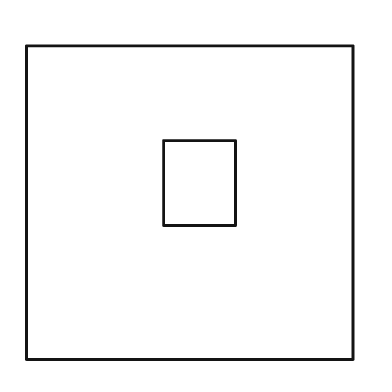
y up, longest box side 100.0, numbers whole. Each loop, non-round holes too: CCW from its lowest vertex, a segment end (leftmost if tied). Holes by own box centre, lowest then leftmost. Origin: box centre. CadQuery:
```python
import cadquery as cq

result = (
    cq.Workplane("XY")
    .moveTo(-50.0, -48.0)
    .lineTo(50.0, -48.0)
    .lineTo(50.0, 48.0)
    .lineTo(-50.0, 48.0)
    .close()
    .moveTo(-8.0, -7.0)
    .lineTo(14.0, -7.0)
    .lineTo(14.0, 19.0)
    .lineTo(-8.0, 19.0)
    .close()
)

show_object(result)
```